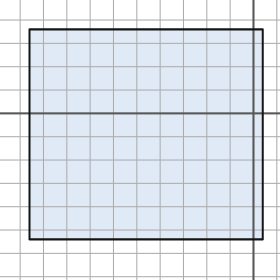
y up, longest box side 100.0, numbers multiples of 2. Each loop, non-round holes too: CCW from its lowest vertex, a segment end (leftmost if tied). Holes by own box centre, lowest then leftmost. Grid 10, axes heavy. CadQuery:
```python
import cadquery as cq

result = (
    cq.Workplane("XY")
    .moveTo(-96.0, -54.0)
    .lineTo(4.0, -54.0)
    .lineTo(4.0, 36.0)
    .lineTo(-96.0, 36.0)
    .close()
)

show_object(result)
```